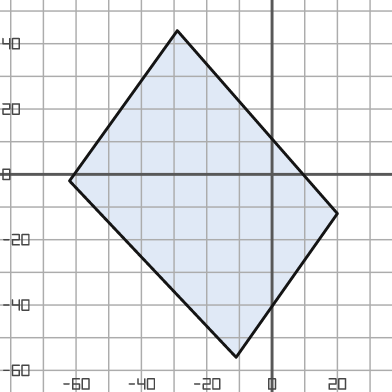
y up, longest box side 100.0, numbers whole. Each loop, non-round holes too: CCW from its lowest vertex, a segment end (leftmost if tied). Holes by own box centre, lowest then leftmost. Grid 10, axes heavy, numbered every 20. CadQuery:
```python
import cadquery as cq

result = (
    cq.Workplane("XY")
    .moveTo(-11.0, -56.0)
    .lineTo(20.0, -12.0)
    .lineTo(-29.0, 44.0)
    .lineTo(-62.0, -2.0)
    .close()
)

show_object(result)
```